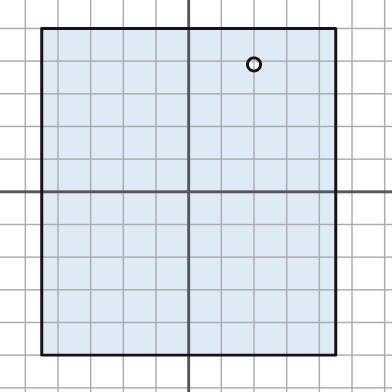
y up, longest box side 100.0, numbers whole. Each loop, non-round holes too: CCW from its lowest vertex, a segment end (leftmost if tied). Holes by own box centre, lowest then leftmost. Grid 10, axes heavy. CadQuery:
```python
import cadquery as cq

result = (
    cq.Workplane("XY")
    .moveTo(-45.0, -50.0)
    .lineTo(45.0, -50.0)
    .lineTo(45.0, 50.0)
    .lineTo(-45.0, 50.0)
    .close()
    .moveTo(20.0, 39.0)
    .circle(2.0)
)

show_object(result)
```